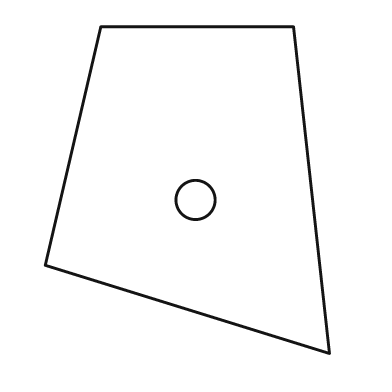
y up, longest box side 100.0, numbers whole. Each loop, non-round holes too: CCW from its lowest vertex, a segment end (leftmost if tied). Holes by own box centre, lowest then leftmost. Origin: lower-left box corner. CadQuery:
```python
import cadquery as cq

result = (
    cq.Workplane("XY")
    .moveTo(87.0, 0.0)
    .lineTo(76.0, 100.0)
    .lineTo(17.0, 100.0)
    .lineTo(0.0, 27.0)
    .close()
    .moveTo(46.0, 47.0)
    .circle(6.0)
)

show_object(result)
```